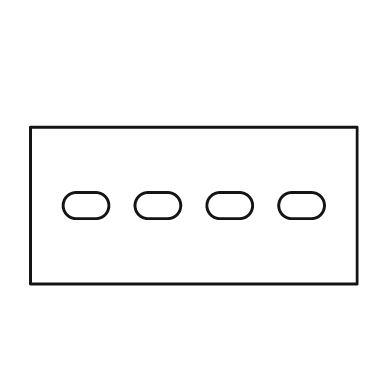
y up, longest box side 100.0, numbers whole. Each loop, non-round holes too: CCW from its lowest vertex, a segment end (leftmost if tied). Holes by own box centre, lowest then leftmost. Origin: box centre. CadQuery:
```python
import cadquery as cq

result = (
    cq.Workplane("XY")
    .moveTo(-50.0, -24.0)
    .lineTo(50.0, -24.0)
    .lineTo(50.0, 24.0)
    .lineTo(-50.0, 24.0)
    .close()
    .moveTo(-36.0, -4.0)
    .lineTo(-30.0, -4.0)
    .threePointArc((-26.0, 0.0), (-30.0, 4.0))
    .lineTo(-36.0, 4.0)
    .threePointArc((-40.0, 0.0), (-36.0, -4.0))
    .close()
    .moveTo(-14.0, -4.0)
    .lineTo(-8.0, -4.0)
    .threePointArc((-4.0, 0.0), (-8.0, 4.0))
    .lineTo(-14.0, 4.0)
    .threePointArc((-18.0, 0.0), (-14.0, -4.0))
    .close()
    .moveTo(8.0, -4.0)
    .lineTo(14.0, -4.0)
    .threePointArc((18.0, 0.0), (14.0, 4.0))
    .lineTo(8.0, 4.0)
    .threePointArc((4.0, 0.0), (8.0, -4.0))
    .close()
    .moveTo(30.0, -4.0)
    .lineTo(36.0, -4.0)
    .threePointArc((40.0, 0.0), (36.0, 4.0))
    .lineTo(30.0, 4.0)
    .threePointArc((26.0, 0.0), (30.0, -4.0))
    .close()
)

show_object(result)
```